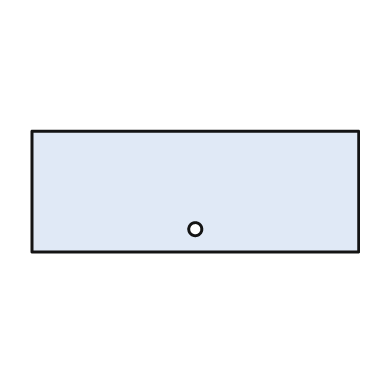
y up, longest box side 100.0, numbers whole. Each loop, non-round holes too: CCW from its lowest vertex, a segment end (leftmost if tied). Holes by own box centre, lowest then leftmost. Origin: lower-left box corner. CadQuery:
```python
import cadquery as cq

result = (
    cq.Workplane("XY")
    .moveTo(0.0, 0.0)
    .lineTo(100.0, 0.0)
    .lineTo(100.0, 37.0)
    .lineTo(0.0, 37.0)
    .close()
    .moveTo(50.0, 7.0)
    .circle(2.0)
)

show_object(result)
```